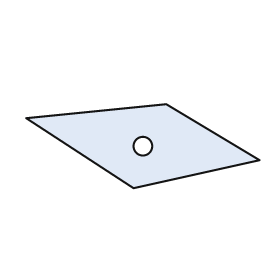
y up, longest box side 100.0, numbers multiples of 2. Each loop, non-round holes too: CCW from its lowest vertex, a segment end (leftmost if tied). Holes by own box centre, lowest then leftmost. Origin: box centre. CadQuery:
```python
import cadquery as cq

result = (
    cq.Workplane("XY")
    .moveTo(-4.0, -18.0)
    .lineTo(50.0, -6.0)
    .lineTo(10.0, 18.0)
    .lineTo(-50.0, 12.0)
    .close()
    .moveTo(0.0, 0.0)
    .circle(4.0)
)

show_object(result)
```